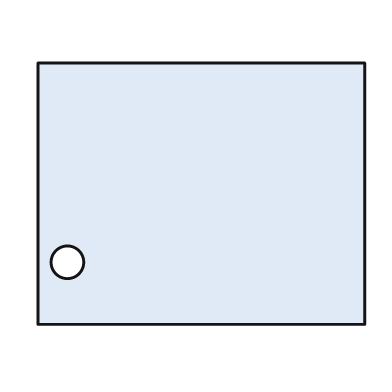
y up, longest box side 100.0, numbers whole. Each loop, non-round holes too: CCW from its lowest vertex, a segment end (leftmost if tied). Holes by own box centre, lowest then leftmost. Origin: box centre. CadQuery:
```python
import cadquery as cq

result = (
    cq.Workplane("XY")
    .moveTo(-50.0, -40.0)
    .lineTo(50.0, -40.0)
    .lineTo(50.0, 40.0)
    .lineTo(-50.0, 40.0)
    .close()
    .moveTo(-41.0, -21.0)
    .circle(5.0)
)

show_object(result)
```